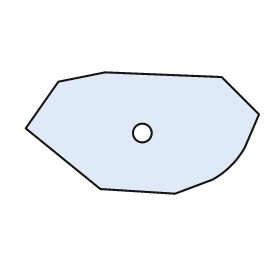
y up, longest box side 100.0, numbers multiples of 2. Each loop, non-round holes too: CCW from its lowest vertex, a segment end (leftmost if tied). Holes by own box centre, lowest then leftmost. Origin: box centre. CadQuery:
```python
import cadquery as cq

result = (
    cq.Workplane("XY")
    .moveTo(14.0, -26.0)
    .lineTo(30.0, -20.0)
    .threePointArc((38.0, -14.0), (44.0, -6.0))
    .lineTo(50.0, 8.0)
    .lineTo(34.0, 24.0)
    .lineTo(-16.0, 26.0)
    .lineTo(-36.0, 22.0)
    .lineTo(-50.0, 2.0)
    .lineTo(-18.0, -24.0)
    .close()
    .moveTo(0.0, 0.0)
    .circle(4.0)
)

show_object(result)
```